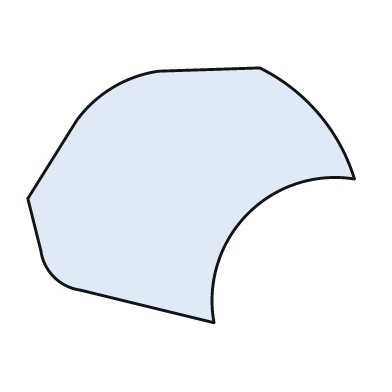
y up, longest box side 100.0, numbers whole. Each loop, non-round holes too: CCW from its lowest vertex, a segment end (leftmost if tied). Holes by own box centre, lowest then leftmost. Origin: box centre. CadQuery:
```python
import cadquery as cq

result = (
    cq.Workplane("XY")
    .moveTo(7.0, -39.0)
    .threePointArc((17.0, -6.0), (50.0, 5.0))
    .threePointArc((39.0, 25.0), (21.0, 39.0))
    .lineTo(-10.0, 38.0)
    .threePointArc((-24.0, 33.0), (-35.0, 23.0))
    .lineTo(-50.0, -1.0)
    .lineTo(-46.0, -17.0)
    .threePointArc((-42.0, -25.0), (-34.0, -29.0))
    .close()
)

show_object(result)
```